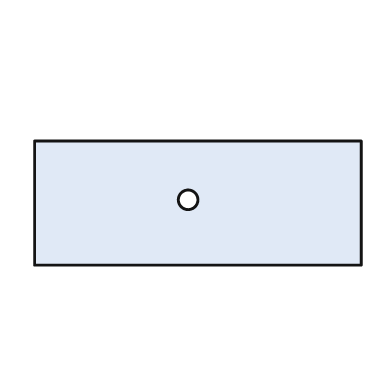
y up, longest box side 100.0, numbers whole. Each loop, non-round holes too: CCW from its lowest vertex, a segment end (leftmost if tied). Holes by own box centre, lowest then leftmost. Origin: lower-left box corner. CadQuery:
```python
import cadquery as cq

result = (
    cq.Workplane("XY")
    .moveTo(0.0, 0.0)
    .lineTo(100.0, 0.0)
    .lineTo(100.0, 38.0)
    .lineTo(0.0, 38.0)
    .close()
    .moveTo(47.0, 20.0)
    .circle(3.0)
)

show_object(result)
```